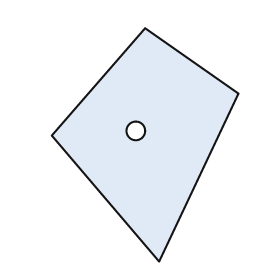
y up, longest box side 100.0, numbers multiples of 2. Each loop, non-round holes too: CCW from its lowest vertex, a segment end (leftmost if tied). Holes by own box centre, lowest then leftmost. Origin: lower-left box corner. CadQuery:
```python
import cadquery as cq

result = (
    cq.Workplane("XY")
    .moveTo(46.0, 0.0)
    .lineTo(80.0, 72.0)
    .lineTo(40.0, 100.0)
    .lineTo(0.0, 54.0)
    .close()
    .moveTo(36.0, 56.0)
    .circle(4.0)
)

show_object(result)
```